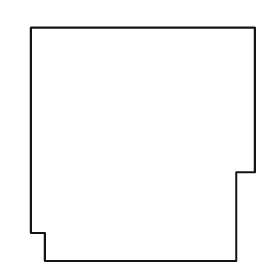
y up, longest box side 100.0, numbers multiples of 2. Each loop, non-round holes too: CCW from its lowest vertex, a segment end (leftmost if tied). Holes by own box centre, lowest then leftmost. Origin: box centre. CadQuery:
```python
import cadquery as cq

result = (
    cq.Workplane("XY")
    .moveTo(-42.0, -50.0)
    .lineTo(40.0, -50.0)
    .lineTo(40.0, -12.0)
    .lineTo(48.0, -12.0)
    .lineTo(48.0, 50.0)
    .lineTo(-48.0, 50.0)
    .lineTo(-48.0, -38.0)
    .lineTo(-42.0, -38.0)
    .close()
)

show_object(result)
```